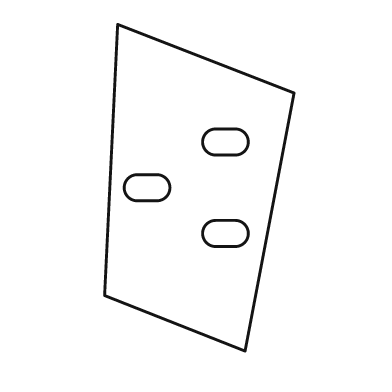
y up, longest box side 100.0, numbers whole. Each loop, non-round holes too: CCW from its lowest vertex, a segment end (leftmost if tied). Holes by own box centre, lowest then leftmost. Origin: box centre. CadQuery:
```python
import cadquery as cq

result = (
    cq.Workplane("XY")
    .moveTo(14.0, -50.0)
    .lineTo(29.0, 29.0)
    .lineTo(-25.0, 50.0)
    .lineTo(-29.0, -33.0)
    .close()
    .moveTo(5.0, -18.0)
    .lineTo(11.0, -18.0)
    .threePointArc((15.0, -14.0), (11.0, -10.0))
    .lineTo(5.0, -10.0)
    .threePointArc((1.0, -14.0), (5.0, -18.0))
    .close()
    .moveTo(-19.0, -4.0)
    .lineTo(-13.0, -4.0)
    .threePointArc((-9.0, 0.0), (-13.0, 4.0))
    .lineTo(-19.0, 4.0)
    .threePointArc((-23.0, 0.0), (-19.0, -4.0))
    .close()
    .moveTo(5.0, 10.0)
    .lineTo(11.0, 10.0)
    .threePointArc((15.0, 14.0), (11.0, 18.0))
    .lineTo(5.0, 18.0)
    .threePointArc((1.0, 14.0), (5.0, 10.0))
    .close()
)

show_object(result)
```